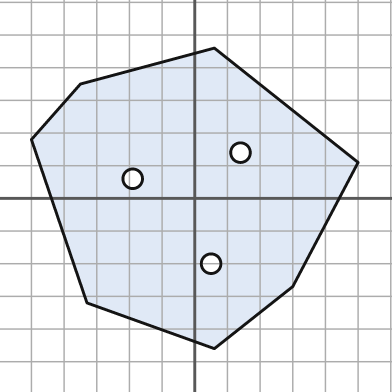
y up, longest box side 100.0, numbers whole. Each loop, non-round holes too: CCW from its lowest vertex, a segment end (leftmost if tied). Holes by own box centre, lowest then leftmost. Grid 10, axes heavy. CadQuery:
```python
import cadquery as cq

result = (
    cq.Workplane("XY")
    .moveTo(6.0, -46.0)
    .lineTo(30.0, -27.0)
    .lineTo(50.0, 11.0)
    .lineTo(6.0, 46.0)
    .lineTo(-35.0, 35.0)
    .lineTo(-50.0, 18.0)
    .lineTo(-33.0, -32.0)
    .close()
    .moveTo(5.0, -20.0)
    .circle(3.0)
    .moveTo(-19.0, 6.0)
    .circle(3.0)
    .moveTo(14.0, 14.0)
    .circle(3.0)
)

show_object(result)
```